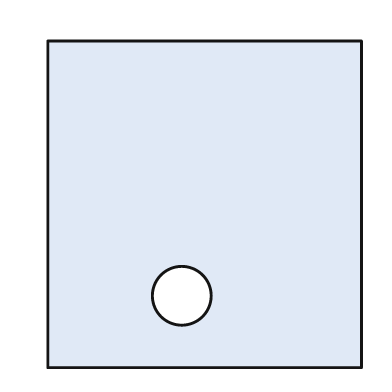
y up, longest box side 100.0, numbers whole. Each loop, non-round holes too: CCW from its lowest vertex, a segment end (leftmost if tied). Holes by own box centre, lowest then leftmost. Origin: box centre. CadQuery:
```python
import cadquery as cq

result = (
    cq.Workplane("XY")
    .moveTo(-48.0, -50.0)
    .lineTo(48.0, -50.0)
    .lineTo(48.0, 50.0)
    .lineTo(-48.0, 50.0)
    .close()
    .moveTo(-7.0, -28.0)
    .circle(9.0)
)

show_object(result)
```